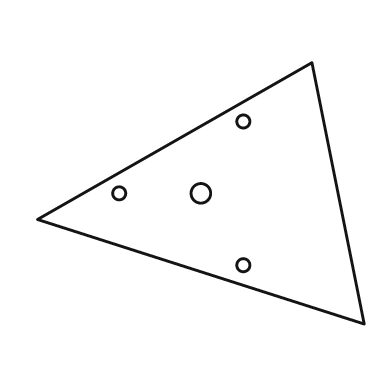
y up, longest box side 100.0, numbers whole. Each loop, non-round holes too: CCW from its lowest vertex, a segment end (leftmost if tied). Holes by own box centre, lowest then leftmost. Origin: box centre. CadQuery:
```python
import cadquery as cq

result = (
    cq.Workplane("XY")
    .moveTo(50.0, -40.0)
    .lineTo(34.0, 40.0)
    .lineTo(-50.0, -8.0)
    .close()
    .moveTo(13.0, -22.0)
    .circle(2.0)
    .moveTo(-25.0, 0.0)
    .circle(2.0)
    .moveTo(0.0, 0.0)
    .circle(3.0)
    .moveTo(13.0, 22.0)
    .circle(2.0)
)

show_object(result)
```